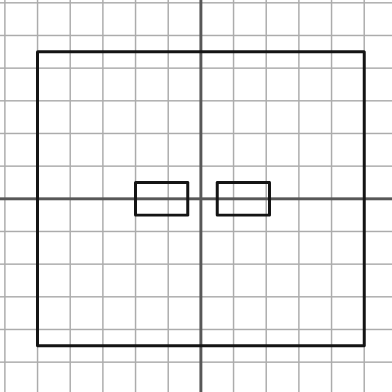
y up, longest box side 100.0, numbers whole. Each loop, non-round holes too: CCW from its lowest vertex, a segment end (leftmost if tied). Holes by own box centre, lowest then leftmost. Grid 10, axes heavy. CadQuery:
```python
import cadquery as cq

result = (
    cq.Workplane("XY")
    .moveTo(-50.0, -45.0)
    .lineTo(50.0, -45.0)
    .lineTo(50.0, 45.0)
    .lineTo(-50.0, 45.0)
    .close()
    .moveTo(-20.0, -5.0)
    .lineTo(-4.0, -5.0)
    .lineTo(-4.0, 5.0)
    .lineTo(-20.0, 5.0)
    .close()
    .moveTo(5.0, -5.0)
    .lineTo(21.0, -5.0)
    .lineTo(21.0, 5.0)
    .lineTo(5.0, 5.0)
    .close()
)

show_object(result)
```